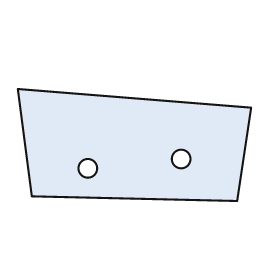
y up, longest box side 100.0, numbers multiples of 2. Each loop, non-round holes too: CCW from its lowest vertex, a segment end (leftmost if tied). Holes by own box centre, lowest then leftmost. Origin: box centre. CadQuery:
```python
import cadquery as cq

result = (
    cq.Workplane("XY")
    .moveTo(44.0, -24.0)
    .lineTo(50.0, 16.0)
    .lineTo(-50.0, 24.0)
    .lineTo(-44.0, -22.0)
    .close()
    .moveTo(-20.0, -10.0)
    .circle(4.0)
    .moveTo(20.0, -6.0)
    .circle(4.0)
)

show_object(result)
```